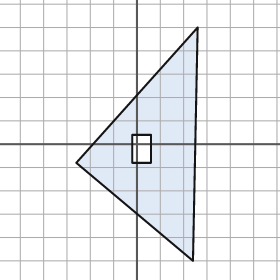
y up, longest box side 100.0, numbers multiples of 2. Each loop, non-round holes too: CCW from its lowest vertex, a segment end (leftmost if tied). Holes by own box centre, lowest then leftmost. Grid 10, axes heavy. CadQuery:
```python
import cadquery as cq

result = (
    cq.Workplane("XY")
    .moveTo(24.0, -50.0)
    .lineTo(26.0, 50.0)
    .lineTo(-26.0, -8.0)
    .close()
    .moveTo(-2.0, -8.0)
    .lineTo(6.0, -8.0)
    .lineTo(6.0, 4.0)
    .lineTo(-2.0, 4.0)
    .close()
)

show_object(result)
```